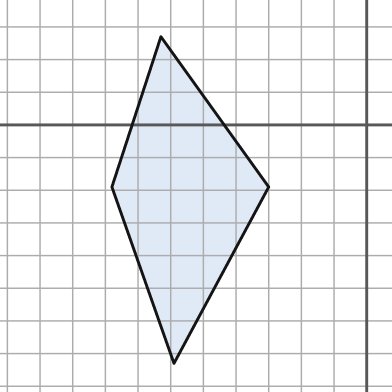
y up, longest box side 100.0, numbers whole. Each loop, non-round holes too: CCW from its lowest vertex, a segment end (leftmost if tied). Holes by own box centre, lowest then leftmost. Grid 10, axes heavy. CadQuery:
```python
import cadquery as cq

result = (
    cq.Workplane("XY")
    .moveTo(-59.0, -73.0)
    .lineTo(-30.0, -19.0)
    .lineTo(-63.0, 27.0)
    .lineTo(-78.0, -19.0)
    .close()
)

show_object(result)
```